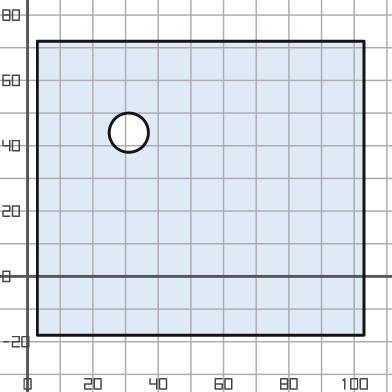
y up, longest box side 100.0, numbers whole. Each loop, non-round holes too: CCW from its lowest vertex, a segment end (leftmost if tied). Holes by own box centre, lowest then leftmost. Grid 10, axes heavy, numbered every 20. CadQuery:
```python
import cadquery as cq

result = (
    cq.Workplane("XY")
    .moveTo(3.0, -18.0)
    .lineTo(103.0, -18.0)
    .lineTo(103.0, 72.0)
    .lineTo(3.0, 72.0)
    .close()
    .moveTo(31.0, 44.0)
    .circle(6.0)
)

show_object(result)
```